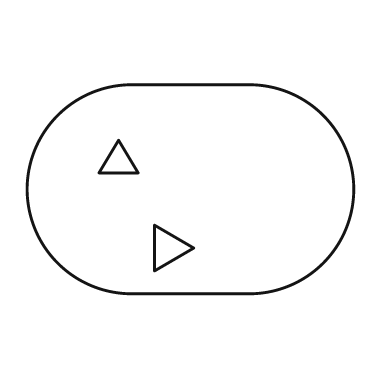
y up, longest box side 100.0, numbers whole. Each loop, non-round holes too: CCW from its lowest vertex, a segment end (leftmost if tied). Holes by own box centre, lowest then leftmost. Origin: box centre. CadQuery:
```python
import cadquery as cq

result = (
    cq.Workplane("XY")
    .moveTo(-18.0, -32.0)
    .lineTo(18.0, -32.0)
    .threePointArc((50.0, 0.0), (18.0, 32.0))
    .lineTo(-18.0, 32.0)
    .threePointArc((-50.0, 0.0), (-18.0, -32.0))
    .close()
    .moveTo(-11.0, -25.0)
    .lineTo(1.0, -18.0)
    .lineTo(-11.0, -11.0)
    .close()
    .moveTo(-28.0, 5.0)
    .lineTo(-16.0, 5.0)
    .lineTo(-22.0, 15.0)
    .close()
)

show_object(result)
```